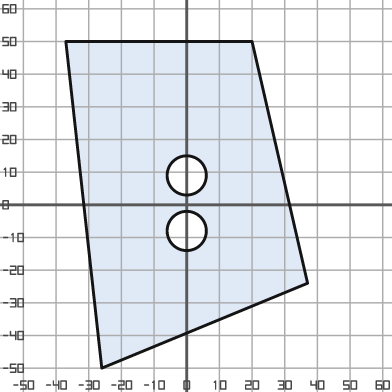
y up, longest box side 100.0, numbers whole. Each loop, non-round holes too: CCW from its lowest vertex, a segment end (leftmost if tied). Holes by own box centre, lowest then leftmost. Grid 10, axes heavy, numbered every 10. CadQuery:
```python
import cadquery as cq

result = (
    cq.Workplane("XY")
    .moveTo(-26.0, -50.0)
    .lineTo(37.0, -24.0)
    .lineTo(20.0, 50.0)
    .lineTo(-37.0, 50.0)
    .close()
    .moveTo(0.0, -8.0)
    .circle(6.0)
    .moveTo(0.0, 9.0)
    .circle(6.0)
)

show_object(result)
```